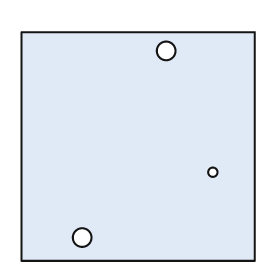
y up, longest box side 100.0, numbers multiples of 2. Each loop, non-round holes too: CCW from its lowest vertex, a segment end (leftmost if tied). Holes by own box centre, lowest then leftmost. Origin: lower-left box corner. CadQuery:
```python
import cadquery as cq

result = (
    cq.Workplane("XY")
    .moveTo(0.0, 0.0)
    .lineTo(100.0, 0.0)
    .lineTo(100.0, 98.0)
    .lineTo(0.0, 98.0)
    .close()
    .moveTo(26.0, 10.0)
    .circle(4.0)
    .moveTo(82.0, 38.0)
    .circle(2.0)
    .moveTo(62.0, 90.0)
    .circle(4.0)
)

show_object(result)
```